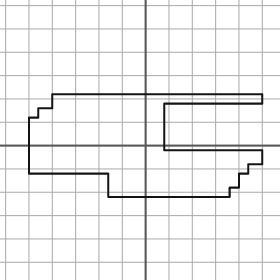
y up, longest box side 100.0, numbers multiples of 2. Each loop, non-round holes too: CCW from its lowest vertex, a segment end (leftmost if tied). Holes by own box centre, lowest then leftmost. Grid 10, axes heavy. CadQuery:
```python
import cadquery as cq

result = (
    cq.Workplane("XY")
    .moveTo(-16.0, -22.0)
    .lineTo(36.0, -22.0)
    .lineTo(36.0, -18.0)
    .lineTo(40.0, -18.0)
    .lineTo(40.0, -12.0)
    .lineTo(44.0, -12.0)
    .lineTo(44.0, -8.0)
    .lineTo(50.0, -8.0)
    .lineTo(50.0, -2.0)
    .lineTo(8.0, -2.0)
    .lineTo(8.0, 18.0)
    .lineTo(50.0, 18.0)
    .lineTo(50.0, 22.0)
    .lineTo(-40.0, 22.0)
    .lineTo(-40.0, 16.0)
    .lineTo(-46.0, 16.0)
    .lineTo(-46.0, 12.0)
    .lineTo(-50.0, 12.0)
    .lineTo(-50.0, -12.0)
    .lineTo(-16.0, -12.0)
    .close()
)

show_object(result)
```